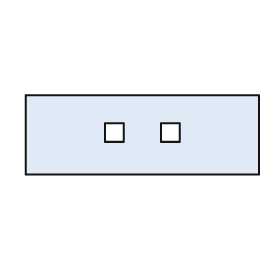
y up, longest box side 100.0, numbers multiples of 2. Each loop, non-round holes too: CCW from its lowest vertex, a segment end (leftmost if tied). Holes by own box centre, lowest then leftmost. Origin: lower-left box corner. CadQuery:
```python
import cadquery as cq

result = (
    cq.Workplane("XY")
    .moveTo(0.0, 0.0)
    .lineTo(100.0, 0.0)
    .lineTo(100.0, 34.0)
    .lineTo(0.0, 34.0)
    .close()
    .moveTo(34.0, 14.0)
    .lineTo(42.0, 14.0)
    .lineTo(42.0, 22.0)
    .lineTo(34.0, 22.0)
    .close()
    .moveTo(58.0, 14.0)
    .lineTo(66.0, 14.0)
    .lineTo(66.0, 22.0)
    .lineTo(58.0, 22.0)
    .close()
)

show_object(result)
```